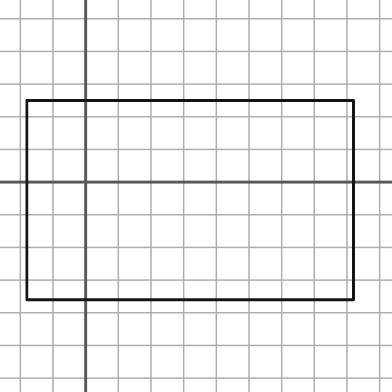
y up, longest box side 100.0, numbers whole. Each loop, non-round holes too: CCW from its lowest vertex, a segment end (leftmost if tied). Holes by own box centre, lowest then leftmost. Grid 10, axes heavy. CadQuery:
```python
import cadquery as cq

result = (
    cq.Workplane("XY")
    .moveTo(-18.0, -36.0)
    .lineTo(82.0, -36.0)
    .lineTo(82.0, 25.0)
    .lineTo(-18.0, 25.0)
    .close()
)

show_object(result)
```